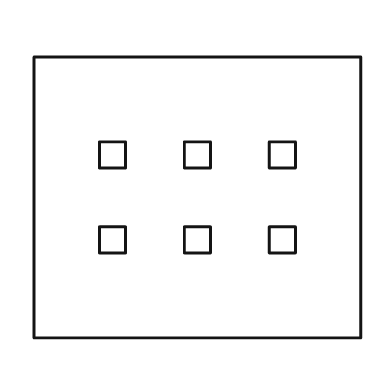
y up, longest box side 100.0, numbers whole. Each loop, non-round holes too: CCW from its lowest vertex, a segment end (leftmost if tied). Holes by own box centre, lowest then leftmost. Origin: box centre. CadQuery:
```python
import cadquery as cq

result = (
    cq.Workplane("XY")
    .moveTo(-50.0, -43.0)
    .lineTo(50.0, -43.0)
    .lineTo(50.0, 43.0)
    .lineTo(-50.0, 43.0)
    .close()
    .moveTo(-30.0, -17.0)
    .lineTo(-22.0, -17.0)
    .lineTo(-22.0, -9.0)
    .lineTo(-30.0, -9.0)
    .close()
    .moveTo(-4.0, -17.0)
    .lineTo(4.0, -17.0)
    .lineTo(4.0, -9.0)
    .lineTo(-4.0, -9.0)
    .close()
    .moveTo(22.0, -17.0)
    .lineTo(30.0, -17.0)
    .lineTo(30.0, -9.0)
    .lineTo(22.0, -9.0)
    .close()
    .moveTo(-30.0, 9.0)
    .lineTo(-22.0, 9.0)
    .lineTo(-22.0, 17.0)
    .lineTo(-30.0, 17.0)
    .close()
    .moveTo(-4.0, 9.0)
    .lineTo(4.0, 9.0)
    .lineTo(4.0, 17.0)
    .lineTo(-4.0, 17.0)
    .close()
    .moveTo(22.0, 9.0)
    .lineTo(30.0, 9.0)
    .lineTo(30.0, 17.0)
    .lineTo(22.0, 17.0)
    .close()
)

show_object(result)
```